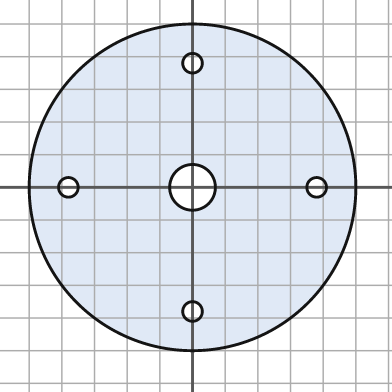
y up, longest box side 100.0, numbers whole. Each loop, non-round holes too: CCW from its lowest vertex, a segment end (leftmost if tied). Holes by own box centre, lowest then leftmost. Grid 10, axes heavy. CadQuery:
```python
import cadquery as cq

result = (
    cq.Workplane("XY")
    .moveTo(0.0, 0.0)
    .circle(50.0)
    .moveTo(0.0, -38.0)
    .circle(3.0)
    .moveTo(-38.0, 0.0)
    .circle(3.0)
    .moveTo(0.0, 0.0)
    .circle(7.0)
    .moveTo(38.0, 0.0)
    .circle(3.0)
    .moveTo(0.0, 38.0)
    .circle(3.0)
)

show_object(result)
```